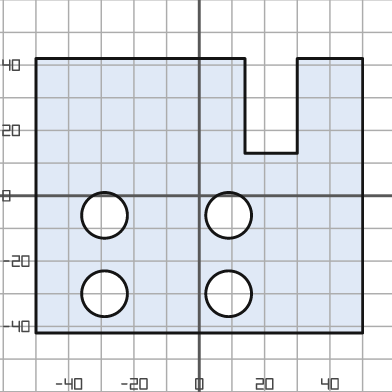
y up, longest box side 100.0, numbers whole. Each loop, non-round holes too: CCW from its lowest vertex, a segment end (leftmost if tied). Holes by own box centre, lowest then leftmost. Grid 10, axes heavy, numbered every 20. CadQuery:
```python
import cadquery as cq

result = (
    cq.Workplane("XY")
    .moveTo(-50.0, -42.0)
    .lineTo(50.0, -42.0)
    .lineTo(50.0, 42.0)
    .lineTo(30.0, 42.0)
    .lineTo(30.0, 13.0)
    .lineTo(14.0, 13.0)
    .lineTo(14.0, 42.0)
    .lineTo(-50.0, 42.0)
    .close()
    .moveTo(-29.0, -30.0)
    .circle(7.0)
    .moveTo(9.0, -30.0)
    .circle(7.0)
    .moveTo(-29.0, -6.0)
    .circle(7.0)
    .moveTo(9.0, -6.0)
    .circle(7.0)
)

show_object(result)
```